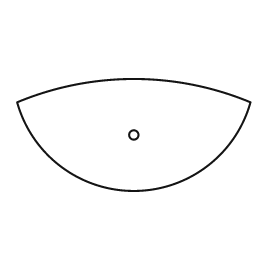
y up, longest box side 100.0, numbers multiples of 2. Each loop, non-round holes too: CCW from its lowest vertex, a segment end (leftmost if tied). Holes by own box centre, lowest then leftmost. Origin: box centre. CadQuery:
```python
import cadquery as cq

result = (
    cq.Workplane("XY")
    .moveTo(-50.0, 14.0)
    .threePointArc((0.0, -24.0), (50.0, 14.0))
    .threePointArc((0.0, 24.0), (-50.0, 14.0))
    .close()
    .moveTo(0.0, 0.0)
    .circle(2.0)
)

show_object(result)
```